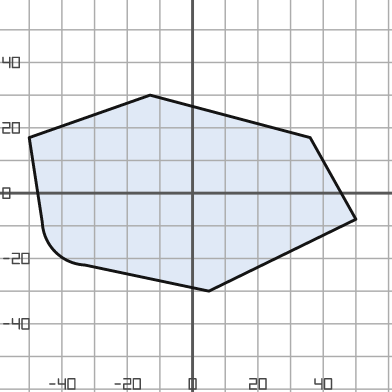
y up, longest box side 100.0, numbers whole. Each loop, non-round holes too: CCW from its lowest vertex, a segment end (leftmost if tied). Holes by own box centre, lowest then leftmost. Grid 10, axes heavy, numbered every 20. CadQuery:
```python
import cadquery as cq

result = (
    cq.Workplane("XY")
    .moveTo(5.0, -30.0)
    .lineTo(50.0, -8.0)
    .lineTo(36.0, 17.0)
    .lineTo(-13.0, 30.0)
    .lineTo(-50.0, 17.0)
    .lineTo(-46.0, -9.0)
    .threePointArc((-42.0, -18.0), (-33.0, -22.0))
    .close()
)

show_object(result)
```